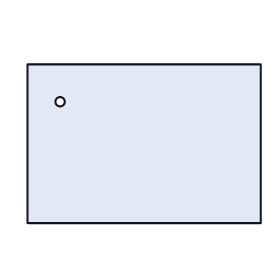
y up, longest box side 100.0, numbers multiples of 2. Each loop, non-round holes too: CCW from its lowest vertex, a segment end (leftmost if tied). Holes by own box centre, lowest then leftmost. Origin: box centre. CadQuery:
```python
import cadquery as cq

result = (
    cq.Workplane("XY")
    .moveTo(-50.0, -34.0)
    .lineTo(50.0, -34.0)
    .lineTo(50.0, 34.0)
    .lineTo(-50.0, 34.0)
    .close()
    .moveTo(-36.0, 18.0)
    .circle(2.0)
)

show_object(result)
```